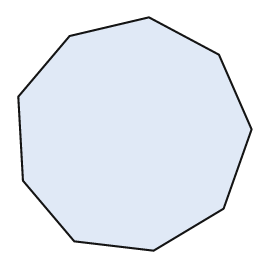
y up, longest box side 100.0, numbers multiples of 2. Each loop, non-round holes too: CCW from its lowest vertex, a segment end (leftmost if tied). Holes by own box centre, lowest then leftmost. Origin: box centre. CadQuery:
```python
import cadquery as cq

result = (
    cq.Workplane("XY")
    .moveTo(8.0, -50.0)
    .lineTo(38.0, -32.0)
    .lineTo(50.0, 2.0)
    .lineTo(36.0, 34.0)
    .lineTo(6.0, 50.0)
    .lineTo(-28.0, 42.0)
    .lineTo(-50.0, 16.0)
    .lineTo(-48.0, -20.0)
    .lineTo(-26.0, -46.0)
    .close()
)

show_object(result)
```